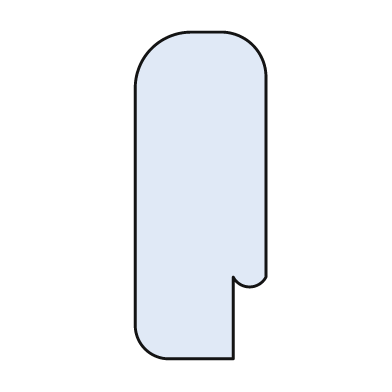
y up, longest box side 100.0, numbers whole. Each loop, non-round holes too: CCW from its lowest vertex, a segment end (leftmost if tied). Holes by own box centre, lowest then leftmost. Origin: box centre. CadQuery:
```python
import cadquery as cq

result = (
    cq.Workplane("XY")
    .moveTo(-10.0, -50.0)
    .lineTo(10.0, -50.0)
    .lineTo(10.0, -25.0)
    .threePointArc((15.0, -28.0), (20.0, -25.0))
    .lineTo(20.0, 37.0)
    .threePointArc((16.0, 46.0), (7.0, 50.0))
    .lineTo(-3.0, 50.0)
    .threePointArc((-15.0, 45.0), (-20.0, 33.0))
    .lineTo(-20.0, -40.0)
    .threePointArc((-17.0, -47.0), (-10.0, -50.0))
    .close()
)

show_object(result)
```